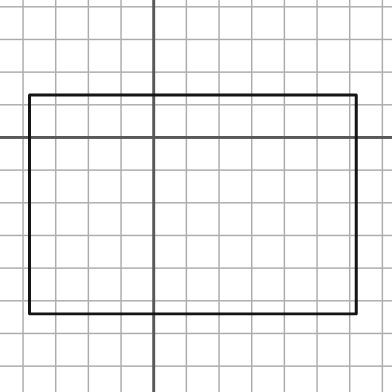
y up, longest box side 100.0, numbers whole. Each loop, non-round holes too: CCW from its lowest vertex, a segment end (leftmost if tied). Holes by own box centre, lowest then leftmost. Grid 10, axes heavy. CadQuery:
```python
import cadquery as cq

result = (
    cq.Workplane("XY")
    .moveTo(-38.0, -54.0)
    .lineTo(62.0, -54.0)
    .lineTo(62.0, 13.0)
    .lineTo(-38.0, 13.0)
    .close()
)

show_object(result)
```